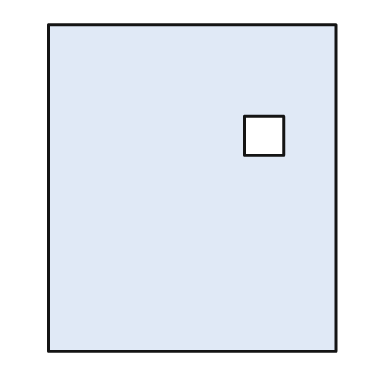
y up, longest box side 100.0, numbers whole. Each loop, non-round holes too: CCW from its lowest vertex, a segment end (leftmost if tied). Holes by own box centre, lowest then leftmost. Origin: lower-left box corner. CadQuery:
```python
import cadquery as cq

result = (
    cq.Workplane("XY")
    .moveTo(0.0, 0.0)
    .lineTo(88.0, 0.0)
    .lineTo(88.0, 100.0)
    .lineTo(0.0, 100.0)
    .close()
    .moveTo(60.0, 60.0)
    .lineTo(72.0, 60.0)
    .lineTo(72.0, 72.0)
    .lineTo(60.0, 72.0)
    .close()
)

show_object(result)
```